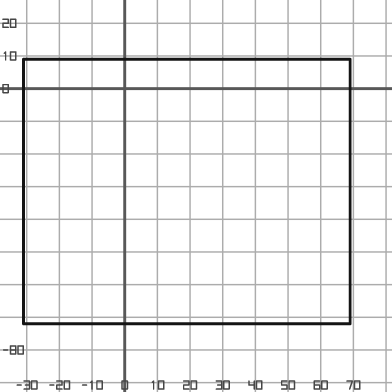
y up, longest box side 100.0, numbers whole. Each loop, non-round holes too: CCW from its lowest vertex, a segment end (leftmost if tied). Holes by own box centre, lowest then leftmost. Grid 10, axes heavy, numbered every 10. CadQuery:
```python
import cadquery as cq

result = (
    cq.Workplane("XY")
    .moveTo(-31.0, -72.0)
    .lineTo(69.0, -72.0)
    .lineTo(69.0, 9.0)
    .lineTo(-31.0, 9.0)
    .close()
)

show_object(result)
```